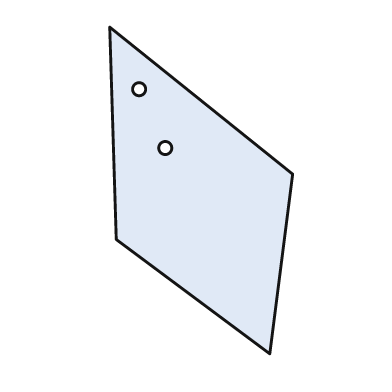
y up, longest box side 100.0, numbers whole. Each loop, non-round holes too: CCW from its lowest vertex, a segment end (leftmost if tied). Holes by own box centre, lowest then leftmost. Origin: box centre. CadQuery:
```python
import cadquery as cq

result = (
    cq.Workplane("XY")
    .moveTo(21.0, -50.0)
    .lineTo(28.0, 5.0)
    .lineTo(-28.0, 50.0)
    .lineTo(-26.0, -15.0)
    .close()
    .moveTo(-11.0, 13.0)
    .circle(2.0)
    .moveTo(-19.0, 31.0)
    .circle(2.0)
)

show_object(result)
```